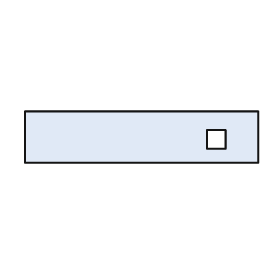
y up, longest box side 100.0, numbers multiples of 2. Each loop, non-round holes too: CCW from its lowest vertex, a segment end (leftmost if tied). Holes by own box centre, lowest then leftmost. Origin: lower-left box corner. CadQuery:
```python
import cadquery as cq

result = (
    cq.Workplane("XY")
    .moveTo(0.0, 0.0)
    .lineTo(100.0, 0.0)
    .lineTo(100.0, 22.0)
    .lineTo(0.0, 22.0)
    .close()
    .moveTo(78.0, 6.0)
    .lineTo(86.0, 6.0)
    .lineTo(86.0, 14.0)
    .lineTo(78.0, 14.0)
    .close()
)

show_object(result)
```